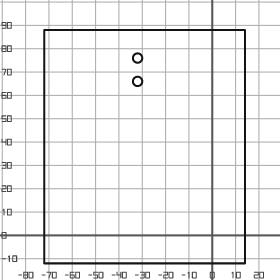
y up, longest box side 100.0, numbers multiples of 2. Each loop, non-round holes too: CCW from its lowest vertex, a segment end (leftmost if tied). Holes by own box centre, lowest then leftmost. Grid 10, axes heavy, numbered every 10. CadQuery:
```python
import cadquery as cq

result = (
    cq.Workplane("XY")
    .moveTo(-72.0, -12.0)
    .lineTo(14.0, -12.0)
    .lineTo(14.0, 88.0)
    .lineTo(-72.0, 88.0)
    .close()
    .moveTo(-32.0, 66.0)
    .circle(2.0)
    .moveTo(-32.0, 76.0)
    .circle(2.0)
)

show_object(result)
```